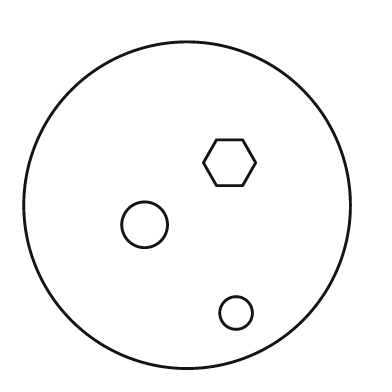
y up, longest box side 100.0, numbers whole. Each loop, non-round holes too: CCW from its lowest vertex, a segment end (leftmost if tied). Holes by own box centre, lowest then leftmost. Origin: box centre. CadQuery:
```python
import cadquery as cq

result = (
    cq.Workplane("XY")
    .moveTo(0.0, 0.0)
    .circle(50.0)
    .moveTo(15.0, -33.0)
    .circle(5.0)
    .moveTo(-13.0, -6.0)
    .circle(7.0)
    .moveTo(9.0, 6.0)
    .lineTo(17.0, 6.0)
    .lineTo(21.0, 13.0)
    .lineTo(17.0, 20.0)
    .lineTo(9.0, 20.0)
    .lineTo(5.0, 13.0)
    .close()
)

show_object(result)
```